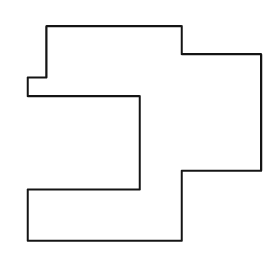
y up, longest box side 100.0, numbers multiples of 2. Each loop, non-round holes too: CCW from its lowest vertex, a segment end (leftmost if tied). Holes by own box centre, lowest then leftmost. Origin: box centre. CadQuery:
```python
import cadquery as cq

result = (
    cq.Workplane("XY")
    .moveTo(-50.0, -46.0)
    .lineTo(16.0, -46.0)
    .lineTo(16.0, -16.0)
    .lineTo(50.0, -16.0)
    .lineTo(50.0, 34.0)
    .lineTo(16.0, 34.0)
    .lineTo(16.0, 46.0)
    .lineTo(-42.0, 46.0)
    .lineTo(-42.0, 24.0)
    .lineTo(-50.0, 24.0)
    .lineTo(-50.0, 16.0)
    .lineTo(-2.0, 16.0)
    .lineTo(-2.0, -24.0)
    .lineTo(-50.0, -24.0)
    .close()
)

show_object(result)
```